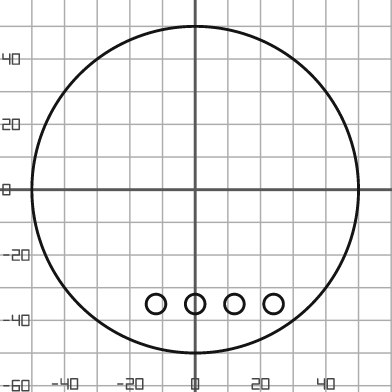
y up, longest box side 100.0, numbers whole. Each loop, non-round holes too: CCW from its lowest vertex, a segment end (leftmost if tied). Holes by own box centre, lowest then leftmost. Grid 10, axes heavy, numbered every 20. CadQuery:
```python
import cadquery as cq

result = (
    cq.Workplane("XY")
    .moveTo(0.0, 0.0)
    .circle(50.0)
    .moveTo(-12.0, -35.0)
    .circle(3.0)
    .moveTo(0.0, -35.0)
    .circle(3.0)
    .moveTo(12.0, -35.0)
    .circle(3.0)
    .moveTo(24.0, -35.0)
    .circle(3.0)
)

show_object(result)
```